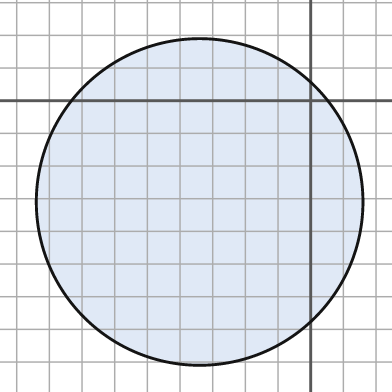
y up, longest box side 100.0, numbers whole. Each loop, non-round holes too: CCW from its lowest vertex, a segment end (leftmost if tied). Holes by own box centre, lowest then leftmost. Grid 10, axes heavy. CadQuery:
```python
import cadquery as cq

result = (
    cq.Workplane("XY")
    .moveTo(-34.0, -31.0)
    .circle(50.0)
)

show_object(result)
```